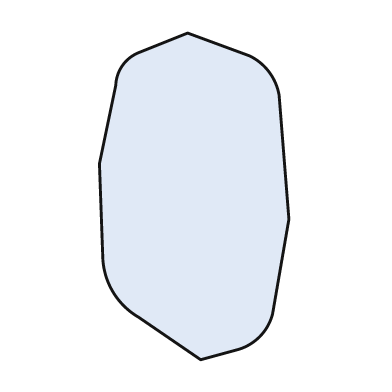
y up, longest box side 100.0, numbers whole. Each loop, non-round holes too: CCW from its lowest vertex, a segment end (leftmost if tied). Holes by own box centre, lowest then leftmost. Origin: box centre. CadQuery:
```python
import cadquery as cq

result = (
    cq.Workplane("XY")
    .moveTo(2.0, -50.0)
    .lineTo(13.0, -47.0)
    .threePointArc((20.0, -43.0), (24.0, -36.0))
    .lineTo(29.0, -7.0)
    .lineTo(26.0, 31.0)
    .threePointArc((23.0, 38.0), (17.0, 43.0))
    .lineTo(-2.0, 50.0)
    .lineTo(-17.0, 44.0)
    .threePointArc((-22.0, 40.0), (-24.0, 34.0))
    .lineTo(-29.0, 10.0)
    .lineTo(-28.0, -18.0)
    .threePointArc((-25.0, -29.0), (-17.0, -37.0))
    .close()
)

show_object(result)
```